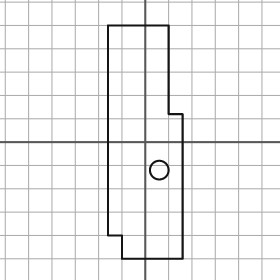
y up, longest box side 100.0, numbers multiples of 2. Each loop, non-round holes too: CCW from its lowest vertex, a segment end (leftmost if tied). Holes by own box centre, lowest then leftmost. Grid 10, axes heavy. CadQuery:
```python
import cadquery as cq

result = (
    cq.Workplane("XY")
    .moveTo(-10.0, -50.0)
    .lineTo(16.0, -50.0)
    .lineTo(16.0, 12.0)
    .lineTo(10.0, 12.0)
    .lineTo(10.0, 50.0)
    .lineTo(-16.0, 50.0)
    .lineTo(-16.0, -40.0)
    .lineTo(-10.0, -40.0)
    .close()
    .moveTo(6.0, -12.0)
    .circle(4.0)
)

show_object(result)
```